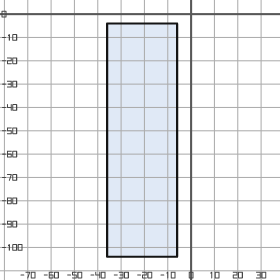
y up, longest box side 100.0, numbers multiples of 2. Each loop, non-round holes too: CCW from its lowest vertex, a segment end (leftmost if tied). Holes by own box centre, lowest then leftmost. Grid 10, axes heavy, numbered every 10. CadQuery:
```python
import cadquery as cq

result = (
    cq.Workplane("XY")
    .moveTo(-36.0, -104.0)
    .lineTo(-6.0, -104.0)
    .lineTo(-6.0, -4.0)
    .lineTo(-36.0, -4.0)
    .close()
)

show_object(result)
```